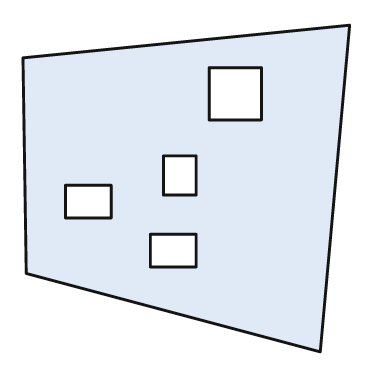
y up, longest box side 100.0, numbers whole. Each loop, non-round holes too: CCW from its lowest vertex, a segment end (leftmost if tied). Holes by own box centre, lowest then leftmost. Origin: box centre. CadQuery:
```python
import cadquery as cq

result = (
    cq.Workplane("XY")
    .moveTo(41.0, -50.0)
    .lineTo(50.0, 50.0)
    .lineTo(-50.0, 40.0)
    .lineTo(-49.0, -26.0)
    .close()
    .moveTo(-11.0, -24.0)
    .lineTo(3.0, -24.0)
    .lineTo(3.0, -14.0)
    .lineTo(-11.0, -14.0)
    .close()
    .moveTo(-37.0, -9.0)
    .lineTo(-23.0, -9.0)
    .lineTo(-23.0, 1.0)
    .lineTo(-37.0, 1.0)
    .close()
    .moveTo(-7.0, -2.0)
    .lineTo(3.0, -2.0)
    .lineTo(3.0, 10.0)
    .lineTo(-7.0, 10.0)
    .close()
    .moveTo(7.0, 21.0)
    .lineTo(23.0, 21.0)
    .lineTo(23.0, 37.0)
    .lineTo(7.0, 37.0)
    .close()
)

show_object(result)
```